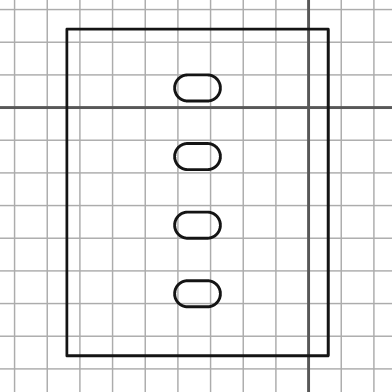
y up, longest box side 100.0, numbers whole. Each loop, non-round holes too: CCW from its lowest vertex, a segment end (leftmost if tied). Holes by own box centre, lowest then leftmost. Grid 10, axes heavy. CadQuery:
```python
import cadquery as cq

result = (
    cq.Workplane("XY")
    .moveTo(-74.0, -76.0)
    .lineTo(6.0, -76.0)
    .lineTo(6.0, 24.0)
    .lineTo(-74.0, 24.0)
    .close()
    .moveTo(-37.0, -61.0)
    .lineTo(-31.0, -61.0)
    .threePointArc((-27.0, -57.0), (-31.0, -53.0))
    .lineTo(-37.0, -53.0)
    .threePointArc((-41.0, -57.0), (-37.0, -61.0))
    .close()
    .moveTo(-37.0, -40.0)
    .lineTo(-31.0, -40.0)
    .threePointArc((-27.0, -36.0), (-31.0, -32.0))
    .lineTo(-37.0, -32.0)
    .threePointArc((-41.0, -36.0), (-37.0, -40.0))
    .close()
    .moveTo(-37.0, -19.0)
    .lineTo(-31.0, -19.0)
    .threePointArc((-27.0, -15.0), (-31.0, -11.0))
    .lineTo(-37.0, -11.0)
    .threePointArc((-41.0, -15.0), (-37.0, -19.0))
    .close()
    .moveTo(-37.0, 2.0)
    .lineTo(-31.0, 2.0)
    .threePointArc((-27.0, 6.0), (-31.0, 10.0))
    .lineTo(-37.0, 10.0)
    .threePointArc((-41.0, 6.0), (-37.0, 2.0))
    .close()
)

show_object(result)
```